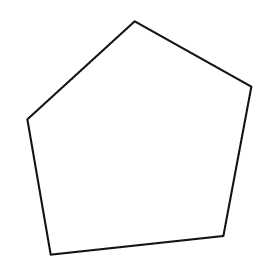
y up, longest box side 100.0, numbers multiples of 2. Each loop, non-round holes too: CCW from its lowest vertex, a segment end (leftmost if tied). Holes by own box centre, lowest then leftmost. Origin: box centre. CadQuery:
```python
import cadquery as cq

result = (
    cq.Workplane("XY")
    .moveTo(-38.0, -50.0)
    .lineTo(36.0, -42.0)
    .lineTo(48.0, 22.0)
    .lineTo(-2.0, 50.0)
    .lineTo(-48.0, 8.0)
    .close()
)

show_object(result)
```